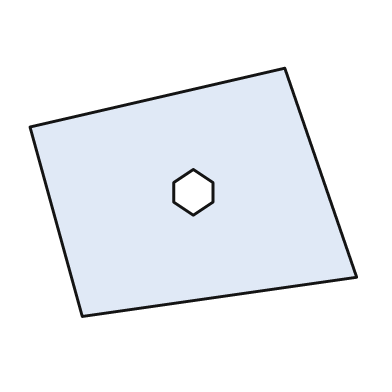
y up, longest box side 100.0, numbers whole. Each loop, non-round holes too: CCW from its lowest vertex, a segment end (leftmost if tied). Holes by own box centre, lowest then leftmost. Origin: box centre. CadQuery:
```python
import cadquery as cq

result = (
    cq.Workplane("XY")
    .moveTo(-34.0, -38.0)
    .lineTo(50.0, -26.0)
    .lineTo(28.0, 38.0)
    .lineTo(-50.0, 20.0)
    .close()
    .moveTo(0.0, -7.0)
    .lineTo(6.0, -3.0)
    .lineTo(6.0, 3.0)
    .lineTo(0.0, 7.0)
    .lineTo(-6.0, 3.0)
    .lineTo(-6.0, -3.0)
    .close()
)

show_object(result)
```